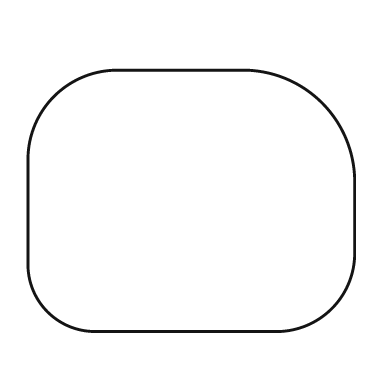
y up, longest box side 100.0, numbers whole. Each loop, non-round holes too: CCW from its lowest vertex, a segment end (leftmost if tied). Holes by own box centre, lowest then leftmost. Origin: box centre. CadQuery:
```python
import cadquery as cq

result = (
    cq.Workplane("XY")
    .moveTo(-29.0, -40.0)
    .lineTo(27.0, -40.0)
    .threePointArc((43.0, -33.0), (50.0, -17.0))
    .lineTo(50.0, 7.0)
    .threePointArc((40.0, 30.0), (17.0, 40.0))
    .lineTo(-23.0, 40.0)
    .threePointArc((-42.0, 32.0), (-50.0, 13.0))
    .lineTo(-50.0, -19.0)
    .threePointArc((-44.0, -34.0), (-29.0, -40.0))
    .close()
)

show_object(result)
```